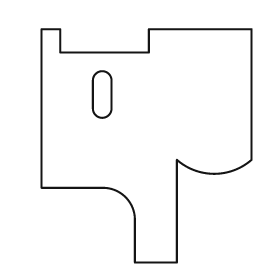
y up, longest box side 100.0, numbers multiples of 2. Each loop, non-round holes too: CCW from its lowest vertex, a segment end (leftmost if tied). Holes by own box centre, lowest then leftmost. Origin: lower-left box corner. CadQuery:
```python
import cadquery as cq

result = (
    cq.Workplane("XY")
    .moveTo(40.0, 0.0)
    .lineTo(58.0, 0.0)
    .lineTo(58.0, 44.0)
    .threePointArc((74.0, 38.0), (90.0, 44.0))
    .lineTo(90.0, 100.0)
    .lineTo(46.0, 100.0)
    .lineTo(46.0, 90.0)
    .lineTo(8.0, 90.0)
    .lineTo(8.0, 100.0)
    .lineTo(0.0, 100.0)
    .lineTo(0.0, 32.0)
    .lineTo(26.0, 32.0)
    .threePointArc((36.0, 28.0), (40.0, 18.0))
    .close()
    .moveTo(22.0, 66.0)
    .threePointArc((26.0, 62.0), (30.0, 66.0))
    .lineTo(30.0, 78.0)
    .threePointArc((26.0, 82.0), (22.0, 78.0))
    .close()
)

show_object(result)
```